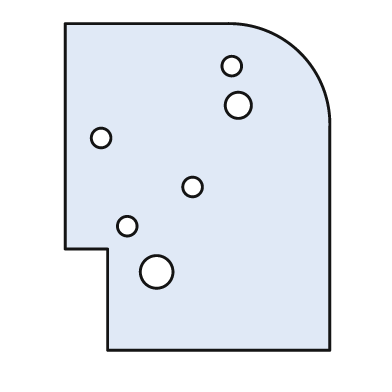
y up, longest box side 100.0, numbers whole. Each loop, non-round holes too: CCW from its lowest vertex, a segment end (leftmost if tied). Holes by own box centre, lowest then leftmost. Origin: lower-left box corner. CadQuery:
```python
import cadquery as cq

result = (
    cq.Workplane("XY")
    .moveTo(13.0, 0.0)
    .lineTo(81.0, 0.0)
    .lineTo(81.0, 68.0)
    .threePointArc((72.0, 91.0), (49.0, 100.0))
    .lineTo(0.0, 100.0)
    .lineTo(0.0, 31.0)
    .lineTo(13.0, 31.0)
    .close()
    .moveTo(28.0, 24.0)
    .circle(5.0)
    .moveTo(19.0, 38.0)
    .circle(3.0)
    .moveTo(39.0, 50.0)
    .circle(3.0)
    .moveTo(11.0, 65.0)
    .circle(3.0)
    .moveTo(53.0, 75.0)
    .circle(4.0)
    .moveTo(51.0, 87.0)
    .circle(3.0)
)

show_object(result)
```